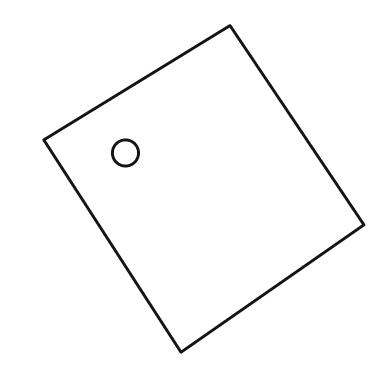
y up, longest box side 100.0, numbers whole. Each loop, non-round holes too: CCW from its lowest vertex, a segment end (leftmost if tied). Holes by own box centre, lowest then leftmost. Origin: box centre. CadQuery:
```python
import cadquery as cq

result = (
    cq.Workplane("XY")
    .moveTo(-7.0, -50.0)
    .lineTo(49.0, -11.0)
    .lineTo(8.0, 50.0)
    .lineTo(-49.0, 15.0)
    .close()
    .moveTo(-24.0, 11.0)
    .circle(4.0)
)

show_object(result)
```